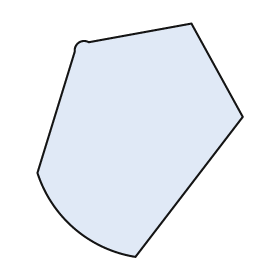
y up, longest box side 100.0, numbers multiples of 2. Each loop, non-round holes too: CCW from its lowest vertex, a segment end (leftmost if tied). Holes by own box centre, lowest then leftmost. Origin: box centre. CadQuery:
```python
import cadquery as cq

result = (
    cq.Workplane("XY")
    .moveTo(-2.0, -50.0)
    .lineTo(44.0, 10.0)
    .lineTo(22.0, 50.0)
    .lineTo(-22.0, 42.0)
    .threePointArc((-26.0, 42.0), (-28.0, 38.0))
    .lineTo(-44.0, -14.0)
    .threePointArc((-28.0, -38.0), (-2.0, -50.0))
    .close()
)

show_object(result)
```